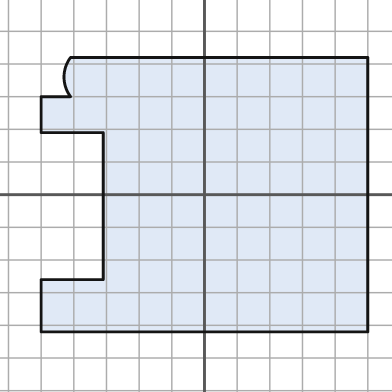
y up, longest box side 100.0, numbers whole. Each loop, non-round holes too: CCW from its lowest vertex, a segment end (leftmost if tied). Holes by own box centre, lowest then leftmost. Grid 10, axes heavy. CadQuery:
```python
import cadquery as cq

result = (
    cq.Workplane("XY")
    .moveTo(-50.0, -42.0)
    .lineTo(50.0, -42.0)
    .lineTo(50.0, 42.0)
    .lineTo(-41.0, 42.0)
    .threePointArc((-43.0, 36.0), (-41.0, 30.0))
    .lineTo(-50.0, 30.0)
    .lineTo(-50.0, 19.0)
    .lineTo(-31.0, 19.0)
    .lineTo(-31.0, -26.0)
    .lineTo(-50.0, -26.0)
    .close()
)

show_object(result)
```